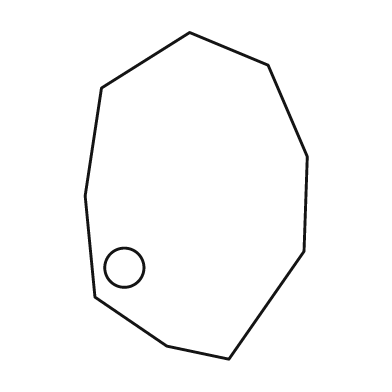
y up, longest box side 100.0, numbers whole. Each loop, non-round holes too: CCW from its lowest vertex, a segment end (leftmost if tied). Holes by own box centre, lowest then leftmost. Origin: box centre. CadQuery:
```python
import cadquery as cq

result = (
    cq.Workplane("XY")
    .moveTo(10.0, -50.0)
    .lineTo(33.0, -17.0)
    .lineTo(34.0, 12.0)
    .lineTo(22.0, 40.0)
    .lineTo(-2.0, 50.0)
    .lineTo(-29.0, 33.0)
    .lineTo(-34.0, 0.0)
    .lineTo(-31.0, -31.0)
    .lineTo(-9.0, -46.0)
    .close()
    .moveTo(-22.0, -22.0)
    .circle(6.0)
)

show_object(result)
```